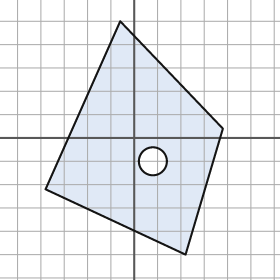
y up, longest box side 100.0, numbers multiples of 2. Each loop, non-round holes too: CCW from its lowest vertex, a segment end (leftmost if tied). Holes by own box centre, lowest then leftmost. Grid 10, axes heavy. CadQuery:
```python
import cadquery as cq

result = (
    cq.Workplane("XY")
    .moveTo(22.0, -50.0)
    .lineTo(38.0, 4.0)
    .lineTo(-6.0, 50.0)
    .lineTo(-38.0, -22.0)
    .close()
    .moveTo(8.0, -10.0)
    .circle(6.0)
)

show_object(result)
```